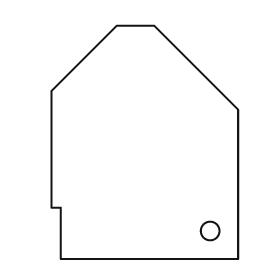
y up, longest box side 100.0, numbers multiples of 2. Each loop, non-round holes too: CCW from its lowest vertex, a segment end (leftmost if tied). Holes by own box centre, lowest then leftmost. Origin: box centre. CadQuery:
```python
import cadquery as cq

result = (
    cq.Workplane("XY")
    .moveTo(-36.0, -50.0)
    .lineTo(40.0, -50.0)
    .lineTo(40.0, 14.0)
    .lineTo(4.0, 50.0)
    .lineTo(-12.0, 50.0)
    .lineTo(-40.0, 22.0)
    .lineTo(-40.0, -28.0)
    .lineTo(-36.0, -28.0)
    .close()
    .moveTo(28.0, -38.0)
    .circle(4.0)
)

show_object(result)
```